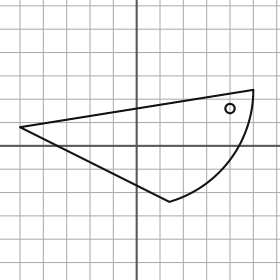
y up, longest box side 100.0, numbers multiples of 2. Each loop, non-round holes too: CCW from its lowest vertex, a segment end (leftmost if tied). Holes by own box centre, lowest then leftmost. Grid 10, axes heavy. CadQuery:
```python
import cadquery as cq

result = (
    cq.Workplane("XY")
    .moveTo(14.0, -24.0)
    .threePointArc((40.0, -6.0), (50.0, 24.0))
    .lineTo(-50.0, 8.0)
    .close()
    .moveTo(40.0, 16.0)
    .circle(2.0)
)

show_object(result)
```